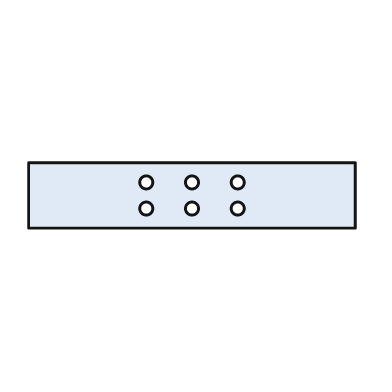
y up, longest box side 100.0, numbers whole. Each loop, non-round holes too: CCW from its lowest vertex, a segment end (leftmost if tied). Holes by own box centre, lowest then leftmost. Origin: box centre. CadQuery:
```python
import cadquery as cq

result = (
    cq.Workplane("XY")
    .moveTo(-50.0, -10.0)
    .lineTo(50.0, -10.0)
    .lineTo(50.0, 10.0)
    .lineTo(-50.0, 10.0)
    .close()
    .moveTo(-14.0, -4.0)
    .circle(2.0)
    .moveTo(0.0, -4.0)
    .circle(2.0)
    .moveTo(14.0, -4.0)
    .circle(2.0)
    .moveTo(-14.0, 4.0)
    .circle(2.0)
    .moveTo(0.0, 4.0)
    .circle(2.0)
    .moveTo(14.0, 4.0)
    .circle(2.0)
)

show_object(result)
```